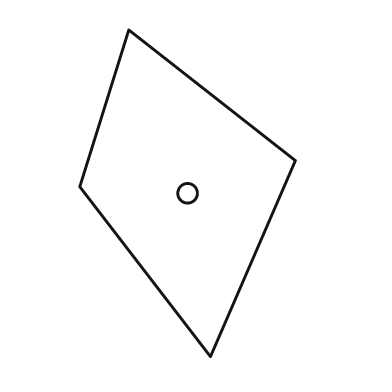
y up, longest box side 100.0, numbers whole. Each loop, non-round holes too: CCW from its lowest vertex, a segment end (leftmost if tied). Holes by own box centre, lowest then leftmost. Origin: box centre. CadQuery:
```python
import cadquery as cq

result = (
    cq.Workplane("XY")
    .moveTo(7.0, -50.0)
    .lineTo(33.0, 10.0)
    .lineTo(-18.0, 50.0)
    .lineTo(-33.0, 2.0)
    .close()
    .moveTo(0.0, 0.0)
    .circle(3.0)
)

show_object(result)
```